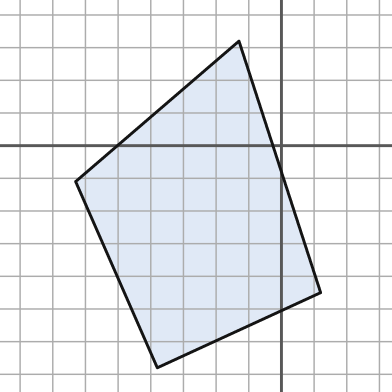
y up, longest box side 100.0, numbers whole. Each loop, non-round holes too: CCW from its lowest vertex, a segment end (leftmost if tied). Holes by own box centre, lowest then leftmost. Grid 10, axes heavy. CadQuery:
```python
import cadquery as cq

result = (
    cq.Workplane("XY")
    .moveTo(-38.0, -68.0)
    .lineTo(12.0, -45.0)
    .lineTo(-13.0, 32.0)
    .lineTo(-63.0, -11.0)
    .close()
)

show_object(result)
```